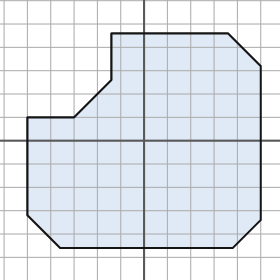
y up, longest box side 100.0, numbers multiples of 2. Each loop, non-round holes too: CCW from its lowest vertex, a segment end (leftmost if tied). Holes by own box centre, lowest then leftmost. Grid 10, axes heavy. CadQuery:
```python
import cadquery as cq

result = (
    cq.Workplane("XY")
    .moveTo(-36.0, -46.0)
    .lineTo(38.0, -46.0)
    .lineTo(50.0, -34.0)
    .lineTo(50.0, 32.0)
    .lineTo(36.0, 46.0)
    .lineTo(-14.0, 46.0)
    .lineTo(-14.0, 26.0)
    .lineTo(-30.0, 10.0)
    .lineTo(-50.0, 10.0)
    .lineTo(-50.0, -32.0)
    .close()
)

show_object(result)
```